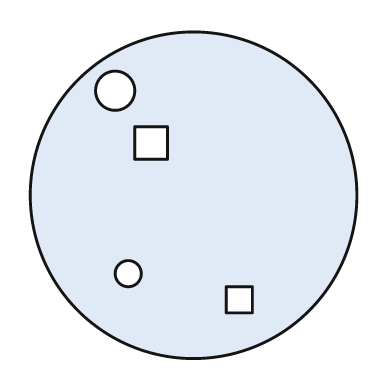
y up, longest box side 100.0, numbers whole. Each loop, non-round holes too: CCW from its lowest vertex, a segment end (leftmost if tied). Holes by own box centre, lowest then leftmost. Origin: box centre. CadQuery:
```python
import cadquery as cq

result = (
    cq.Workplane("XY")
    .moveTo(0.0, 0.0)
    .circle(50.0)
    .moveTo(10.0, -36.0)
    .lineTo(18.0, -36.0)
    .lineTo(18.0, -28.0)
    .lineTo(10.0, -28.0)
    .close()
    .moveTo(-20.0, -24.0)
    .circle(4.0)
    .moveTo(-18.0, 11.0)
    .lineTo(-8.0, 11.0)
    .lineTo(-8.0, 21.0)
    .lineTo(-18.0, 21.0)
    .close()
    .moveTo(-24.0, 32.0)
    .circle(6.0)
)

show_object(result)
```